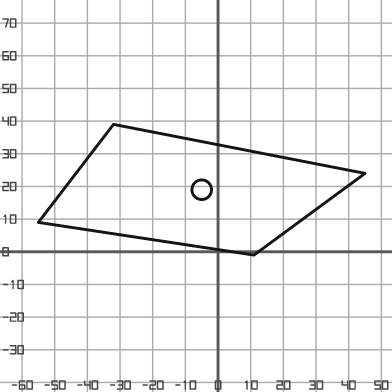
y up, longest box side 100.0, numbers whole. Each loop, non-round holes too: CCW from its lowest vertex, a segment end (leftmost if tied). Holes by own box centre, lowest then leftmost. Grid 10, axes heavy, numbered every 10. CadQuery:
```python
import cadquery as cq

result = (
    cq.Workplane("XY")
    .moveTo(11.0, -1.0)
    .lineTo(45.0, 24.0)
    .lineTo(-32.0, 39.0)
    .lineTo(-55.0, 9.0)
    .close()
    .moveTo(-5.0, 19.0)
    .circle(3.0)
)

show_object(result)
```